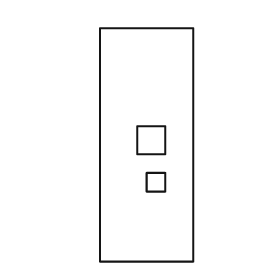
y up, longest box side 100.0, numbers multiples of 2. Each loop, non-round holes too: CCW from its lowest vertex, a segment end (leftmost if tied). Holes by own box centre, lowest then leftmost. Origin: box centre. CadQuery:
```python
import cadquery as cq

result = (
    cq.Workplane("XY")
    .moveTo(-20.0, -50.0)
    .lineTo(20.0, -50.0)
    .lineTo(20.0, 50.0)
    .lineTo(-20.0, 50.0)
    .close()
    .moveTo(0.0, -20.0)
    .lineTo(8.0, -20.0)
    .lineTo(8.0, -12.0)
    .lineTo(0.0, -12.0)
    .close()
    .moveTo(-4.0, -4.0)
    .lineTo(8.0, -4.0)
    .lineTo(8.0, 8.0)
    .lineTo(-4.0, 8.0)
    .close()
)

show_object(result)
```